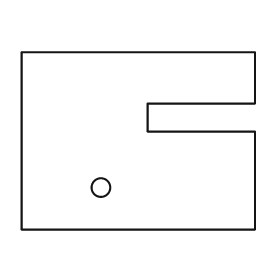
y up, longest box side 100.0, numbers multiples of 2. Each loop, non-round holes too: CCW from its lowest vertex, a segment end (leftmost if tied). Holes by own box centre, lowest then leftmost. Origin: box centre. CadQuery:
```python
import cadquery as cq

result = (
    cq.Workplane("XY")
    .moveTo(-50.0, -38.0)
    .lineTo(50.0, -38.0)
    .lineTo(50.0, 4.0)
    .lineTo(4.0, 4.0)
    .lineTo(4.0, 16.0)
    .lineTo(50.0, 16.0)
    .lineTo(50.0, 38.0)
    .lineTo(-50.0, 38.0)
    .close()
    .moveTo(-16.0, -20.0)
    .circle(4.0)
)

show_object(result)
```